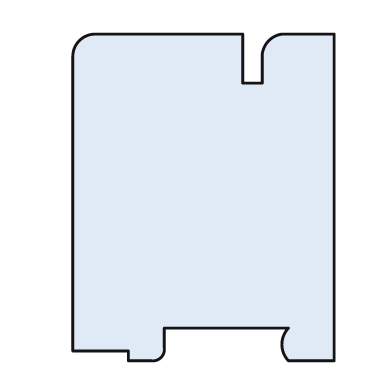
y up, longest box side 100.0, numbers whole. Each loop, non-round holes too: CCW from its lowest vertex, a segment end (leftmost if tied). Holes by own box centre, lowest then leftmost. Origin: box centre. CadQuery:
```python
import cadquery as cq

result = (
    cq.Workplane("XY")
    .moveTo(-23.0, -50.0)
    .lineTo(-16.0, -50.0)
    .threePointArc((-13.0, -49.0), (-12.0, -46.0))
    .lineTo(-12.0, -40.0)
    .lineTo(26.0, -40.0)
    .threePointArc((24.0, -45.0), (26.0, -50.0))
    .lineTo(40.0, -50.0)
    .lineTo(40.0, 50.0)
    .lineTo(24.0, 50.0)
    .threePointArc((20.0, 48.0), (18.0, 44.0))
    .lineTo(18.0, 35.0)
    .lineTo(12.0, 35.0)
    .lineTo(12.0, 50.0)
    .lineTo(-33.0, 50.0)
    .threePointArc((-38.0, 48.0), (-40.0, 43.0))
    .lineTo(-40.0, -47.0)
    .lineTo(-23.0, -47.0)
    .close()
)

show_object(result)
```